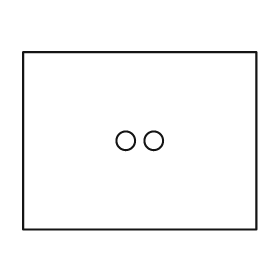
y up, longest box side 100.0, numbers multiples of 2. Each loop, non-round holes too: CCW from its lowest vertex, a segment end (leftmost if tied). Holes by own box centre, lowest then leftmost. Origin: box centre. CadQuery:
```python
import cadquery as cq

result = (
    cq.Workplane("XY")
    .moveTo(-50.0, -38.0)
    .lineTo(50.0, -38.0)
    .lineTo(50.0, 38.0)
    .lineTo(-50.0, 38.0)
    .close()
    .moveTo(-6.0, 0.0)
    .circle(4.0)
    .moveTo(6.0, 0.0)
    .circle(4.0)
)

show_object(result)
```